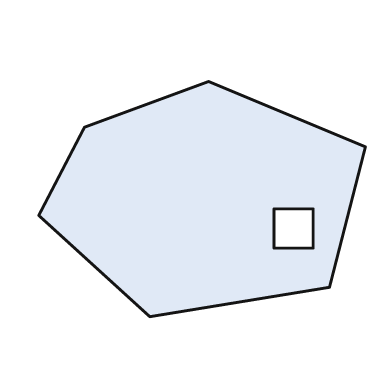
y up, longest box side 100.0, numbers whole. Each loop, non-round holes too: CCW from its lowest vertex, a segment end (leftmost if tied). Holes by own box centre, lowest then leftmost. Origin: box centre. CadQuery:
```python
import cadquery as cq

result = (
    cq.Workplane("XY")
    .moveTo(-16.0, -36.0)
    .lineTo(39.0, -27.0)
    .lineTo(50.0, 16.0)
    .lineTo(2.0, 36.0)
    .lineTo(-36.0, 22.0)
    .lineTo(-50.0, -5.0)
    .close()
    .moveTo(22.0, -15.0)
    .lineTo(34.0, -15.0)
    .lineTo(34.0, -3.0)
    .lineTo(22.0, -3.0)
    .close()
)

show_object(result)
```